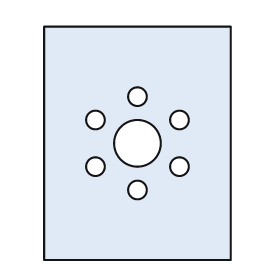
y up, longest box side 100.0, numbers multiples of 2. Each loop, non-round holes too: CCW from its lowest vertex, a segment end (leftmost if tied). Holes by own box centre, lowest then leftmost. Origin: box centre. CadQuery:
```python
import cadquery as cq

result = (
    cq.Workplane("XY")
    .moveTo(-40.0, -50.0)
    .lineTo(40.0, -50.0)
    .lineTo(40.0, 50.0)
    .lineTo(-40.0, 50.0)
    .close()
    .moveTo(0.0, -20.0)
    .circle(4.0)
    .moveTo(-18.0, -10.0)
    .circle(4.0)
    .moveTo(18.0, -10.0)
    .circle(4.0)
    .moveTo(0.0, 0.0)
    .circle(10.0)
    .moveTo(-18.0, 10.0)
    .circle(4.0)
    .moveTo(18.0, 10.0)
    .circle(4.0)
    .moveTo(0.0, 20.0)
    .circle(4.0)
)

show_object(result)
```